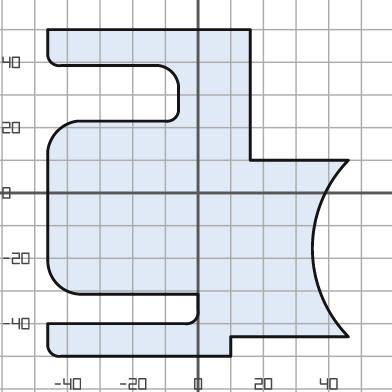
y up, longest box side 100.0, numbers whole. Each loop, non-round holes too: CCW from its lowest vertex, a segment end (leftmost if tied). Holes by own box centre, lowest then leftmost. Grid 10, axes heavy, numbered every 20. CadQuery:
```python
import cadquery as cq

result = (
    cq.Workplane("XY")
    .moveTo(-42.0, -50.0)
    .lineTo(10.0, -50.0)
    .lineTo(10.0, -44.0)
    .lineTo(46.0, -44.0)
    .threePointArc((35.0, -17.0), (46.0, 10.0))
    .lineTo(16.0, 10.0)
    .lineTo(16.0, 50.0)
    .lineTo(-46.0, 50.0)
    .lineTo(-46.0, 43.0)
    .threePointArc((-45.0, 40.0), (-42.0, 39.0))
    .lineTo(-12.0, 39.0)
    .threePointArc((-8.0, 37.0), (-6.0, 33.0))
    .lineTo(-6.0, 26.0)
    .threePointArc((-7.0, 23.0), (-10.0, 22.0))
    .lineTo(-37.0, 22.0)
    .threePointArc((-43.0, 19.0), (-46.0, 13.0))
    .lineTo(-46.0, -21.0)
    .threePointArc((-43.0, -28.0), (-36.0, -31.0))
    .lineTo(0.0, -31.0)
    .lineTo(0.0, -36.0)
    .threePointArc((-1.0, -39.0), (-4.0, -40.0))
    .lineTo(-46.0, -40.0)
    .lineTo(-46.0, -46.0)
    .threePointArc((-45.0, -49.0), (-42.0, -50.0))
    .close()
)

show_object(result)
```